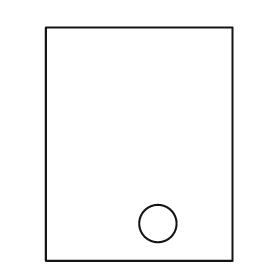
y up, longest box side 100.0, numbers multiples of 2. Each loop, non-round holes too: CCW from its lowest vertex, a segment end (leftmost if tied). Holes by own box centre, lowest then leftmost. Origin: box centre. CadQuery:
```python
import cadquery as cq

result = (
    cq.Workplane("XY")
    .moveTo(-40.0, -50.0)
    .lineTo(40.0, -50.0)
    .lineTo(40.0, 50.0)
    .lineTo(-40.0, 50.0)
    .close()
    .moveTo(8.0, -34.0)
    .circle(8.0)
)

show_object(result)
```